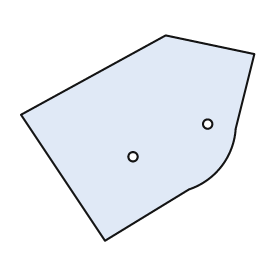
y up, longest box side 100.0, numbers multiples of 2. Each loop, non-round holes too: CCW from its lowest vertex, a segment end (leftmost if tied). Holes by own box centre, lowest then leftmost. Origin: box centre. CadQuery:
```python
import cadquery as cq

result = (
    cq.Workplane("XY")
    .moveTo(-14.0, -44.0)
    .lineTo(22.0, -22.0)
    .threePointArc((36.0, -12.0), (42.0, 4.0))
    .lineTo(50.0, 36.0)
    .lineTo(12.0, 44.0)
    .lineTo(-50.0, 10.0)
    .close()
    .moveTo(-2.0, -8.0)
    .circle(2.0)
    .moveTo(30.0, 6.0)
    .circle(2.0)
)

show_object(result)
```